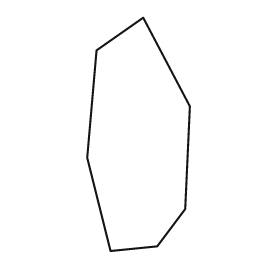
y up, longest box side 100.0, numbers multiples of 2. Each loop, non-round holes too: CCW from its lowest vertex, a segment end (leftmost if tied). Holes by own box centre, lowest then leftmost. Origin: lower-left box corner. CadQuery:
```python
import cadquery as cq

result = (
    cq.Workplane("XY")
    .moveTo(10.0, 0.0)
    .lineTo(30.0, 2.0)
    .lineTo(42.0, 18.0)
    .lineTo(44.0, 62.0)
    .lineTo(24.0, 100.0)
    .lineTo(4.0, 86.0)
    .lineTo(0.0, 40.0)
    .close()
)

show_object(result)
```